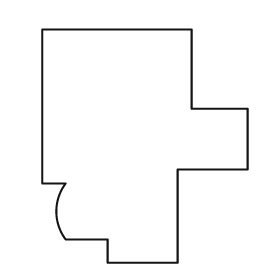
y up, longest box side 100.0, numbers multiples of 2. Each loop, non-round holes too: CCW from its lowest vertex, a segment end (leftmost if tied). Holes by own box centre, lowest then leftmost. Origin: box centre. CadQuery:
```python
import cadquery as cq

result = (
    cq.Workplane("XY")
    .moveTo(-16.0, -50.0)
    .lineTo(14.0, -50.0)
    .lineTo(14.0, -10.0)
    .lineTo(44.0, -10.0)
    .lineTo(44.0, 16.0)
    .lineTo(20.0, 16.0)
    .lineTo(20.0, 50.0)
    .lineTo(-44.0, 50.0)
    .lineTo(-44.0, -16.0)
    .lineTo(-34.0, -16.0)
    .threePointArc((-38.0, -28.0), (-34.0, -40.0))
    .lineTo(-16.0, -40.0)
    .close()
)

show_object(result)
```